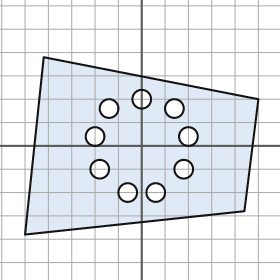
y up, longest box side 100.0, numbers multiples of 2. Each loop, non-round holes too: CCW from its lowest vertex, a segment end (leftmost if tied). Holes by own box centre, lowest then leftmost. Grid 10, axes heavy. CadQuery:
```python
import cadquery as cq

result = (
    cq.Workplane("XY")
    .moveTo(-50.0, -38.0)
    .lineTo(44.0, -28.0)
    .lineTo(50.0, 20.0)
    .lineTo(-42.0, 38.0)
    .close()
    .moveTo(-6.0, -20.0)
    .circle(4.0)
    .moveTo(6.0, -20.0)
    .circle(4.0)
    .moveTo(-18.0, -10.0)
    .circle(4.0)
    .moveTo(18.0, -10.0)
    .circle(4.0)
    .moveTo(-20.0, 4.0)
    .circle(4.0)
    .moveTo(20.0, 4.0)
    .circle(4.0)
    .moveTo(-14.0, 16.0)
    .circle(4.0)
    .moveTo(14.0, 16.0)
    .circle(4.0)
    .moveTo(0.0, 20.0)
    .circle(4.0)
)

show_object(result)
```